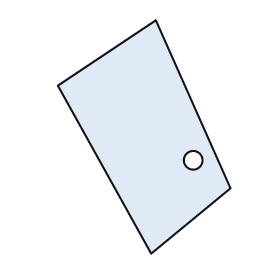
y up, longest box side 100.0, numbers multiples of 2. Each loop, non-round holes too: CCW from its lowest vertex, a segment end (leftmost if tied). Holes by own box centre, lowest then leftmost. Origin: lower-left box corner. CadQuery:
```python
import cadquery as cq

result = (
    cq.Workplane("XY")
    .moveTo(40.0, 0.0)
    .lineTo(74.0, 28.0)
    .lineTo(42.0, 100.0)
    .lineTo(0.0, 72.0)
    .close()
    .moveTo(58.0, 40.0)
    .circle(4.0)
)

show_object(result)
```